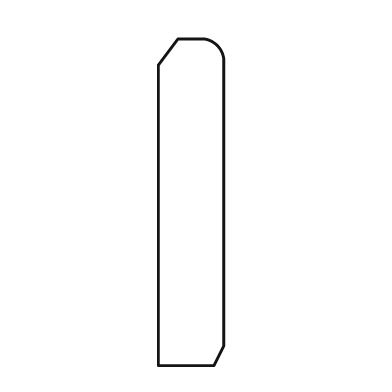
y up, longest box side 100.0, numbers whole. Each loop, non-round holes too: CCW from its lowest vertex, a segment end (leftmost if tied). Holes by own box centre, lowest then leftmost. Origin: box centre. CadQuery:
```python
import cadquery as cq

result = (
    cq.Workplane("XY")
    .moveTo(-10.0, -50.0)
    .lineTo(7.0, -50.0)
    .lineTo(10.0, -44.0)
    .lineTo(10.0, 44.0)
    .threePointArc((8.0, 48.0), (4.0, 50.0))
    .lineTo(-4.0, 50.0)
    .lineTo(-10.0, 42.0)
    .close()
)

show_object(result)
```